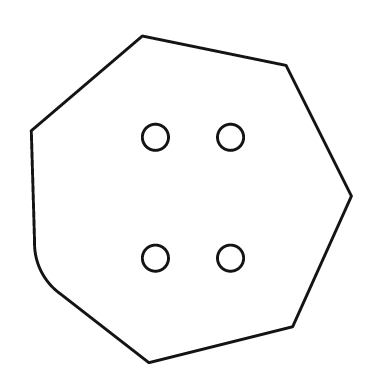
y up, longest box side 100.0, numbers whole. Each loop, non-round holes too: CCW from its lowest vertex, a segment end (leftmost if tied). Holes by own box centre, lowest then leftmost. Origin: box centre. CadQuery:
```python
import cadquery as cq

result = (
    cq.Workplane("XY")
    .moveTo(-13.0, -50.0)
    .lineTo(31.0, -39.0)
    .lineTo(49.0, 1.0)
    .lineTo(29.0, 41.0)
    .lineTo(-15.0, 50.0)
    .lineTo(-49.0, 21.0)
    .lineTo(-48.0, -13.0)
    .threePointArc((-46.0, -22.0), (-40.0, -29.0))
    .close()
    .moveTo(-11.0, -18.0)
    .circle(4.0)
    .moveTo(12.0, -18.0)
    .circle(4.0)
    .moveTo(-11.0, 19.0)
    .circle(4.0)
    .moveTo(12.0, 19.0)
    .circle(4.0)
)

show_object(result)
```